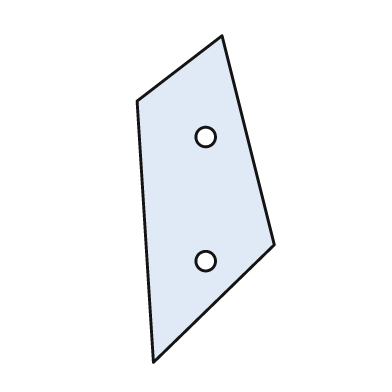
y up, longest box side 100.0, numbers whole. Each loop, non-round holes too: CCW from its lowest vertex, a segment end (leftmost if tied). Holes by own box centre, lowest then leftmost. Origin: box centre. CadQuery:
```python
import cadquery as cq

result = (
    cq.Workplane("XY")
    .moveTo(-16.0, -50.0)
    .lineTo(21.0, -14.0)
    .lineTo(5.0, 50.0)
    .lineTo(-21.0, 30.0)
    .close()
    .moveTo(0.0, -19.0)
    .circle(3.0)
    .moveTo(0.0, 19.0)
    .circle(3.0)
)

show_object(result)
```